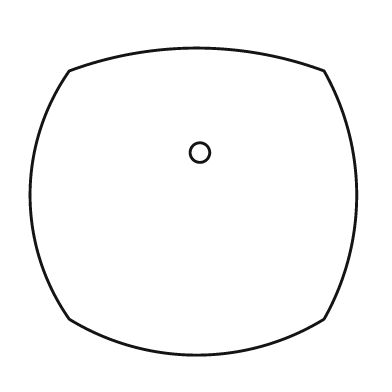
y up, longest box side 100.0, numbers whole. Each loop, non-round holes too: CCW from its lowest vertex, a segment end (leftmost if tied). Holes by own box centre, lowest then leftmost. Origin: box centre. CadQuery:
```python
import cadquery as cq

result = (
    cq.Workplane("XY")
    .moveTo(-38.0, -36.0)
    .threePointArc((1.0, -47.0), (40.0, -36.0))
    .threePointArc((50.0, 2.0), (40.0, 40.0))
    .threePointArc((1.0, 47.0), (-38.0, 40.0))
    .threePointArc((-50.0, 2.0), (-38.0, -36.0))
    .close()
    .moveTo(2.0, 15.0)
    .circle(3.0)
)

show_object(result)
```